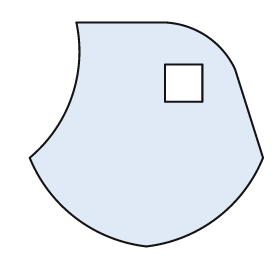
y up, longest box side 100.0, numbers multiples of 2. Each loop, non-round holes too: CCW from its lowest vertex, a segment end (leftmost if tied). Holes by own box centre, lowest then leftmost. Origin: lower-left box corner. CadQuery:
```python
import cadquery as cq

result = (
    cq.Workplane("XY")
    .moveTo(50.0, 0.0)
    .threePointArc((80.0, 12.0), (100.0, 38.0))
    .lineTo(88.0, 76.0)
    .threePointArc((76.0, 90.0), (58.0, 96.0))
    .lineTo(20.0, 96.0)
    .threePointArc((18.0, 64.0), (0.0, 38.0))
    .threePointArc((20.0, 12.0), (50.0, 0.0))
    .close()
    .moveTo(58.0, 62.0)
    .lineTo(74.0, 62.0)
    .lineTo(74.0, 78.0)
    .lineTo(58.0, 78.0)
    .close()
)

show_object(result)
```